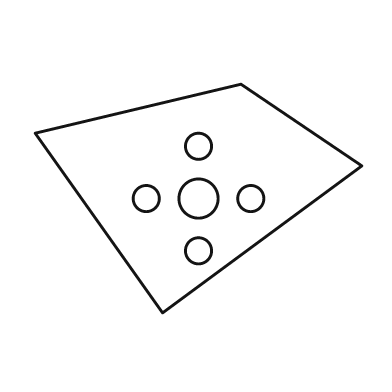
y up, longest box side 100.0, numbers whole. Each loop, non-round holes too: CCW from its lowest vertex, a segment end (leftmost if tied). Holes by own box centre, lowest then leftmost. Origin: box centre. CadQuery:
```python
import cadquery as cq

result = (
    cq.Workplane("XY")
    .moveTo(-11.0, -35.0)
    .lineTo(50.0, 10.0)
    .lineTo(13.0, 35.0)
    .lineTo(-50.0, 20.0)
    .close()
    .moveTo(0.0, -16.0)
    .circle(4.0)
    .moveTo(-16.0, 0.0)
    .circle(4.0)
    .moveTo(0.0, 0.0)
    .circle(6.0)
    .moveTo(16.0, 0.0)
    .circle(4.0)
    .moveTo(0.0, 16.0)
    .circle(4.0)
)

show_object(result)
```